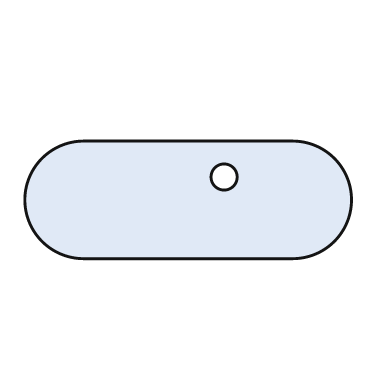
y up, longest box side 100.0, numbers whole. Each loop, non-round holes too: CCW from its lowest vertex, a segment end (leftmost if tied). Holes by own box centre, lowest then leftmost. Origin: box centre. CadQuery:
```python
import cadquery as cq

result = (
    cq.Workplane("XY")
    .moveTo(-32.0, -18.0)
    .lineTo(32.0, -18.0)
    .threePointArc((50.0, 0.0), (32.0, 18.0))
    .lineTo(-32.0, 18.0)
    .threePointArc((-50.0, 0.0), (-32.0, -18.0))
    .close()
    .moveTo(11.0, 7.0)
    .circle(4.0)
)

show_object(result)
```